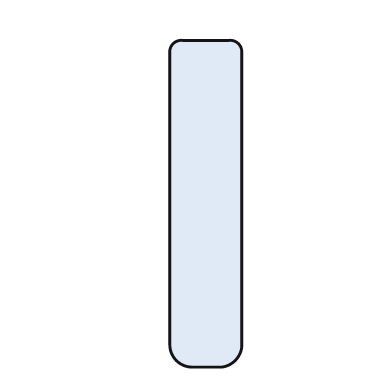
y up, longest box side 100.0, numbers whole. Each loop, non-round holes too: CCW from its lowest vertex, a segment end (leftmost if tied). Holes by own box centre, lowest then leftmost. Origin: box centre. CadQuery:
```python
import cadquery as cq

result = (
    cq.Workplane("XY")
    .moveTo(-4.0, -50.0)
    .lineTo(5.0, -50.0)
    .threePointArc((9.0, -48.0), (11.0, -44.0))
    .lineTo(11.0, 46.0)
    .threePointArc((10.0, 49.0), (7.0, 50.0))
    .lineTo(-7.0, 50.0)
    .threePointArc((-10.0, 49.0), (-11.0, 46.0))
    .lineTo(-11.0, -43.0)
    .threePointArc((-9.0, -48.0), (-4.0, -50.0))
    .close()
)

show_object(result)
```